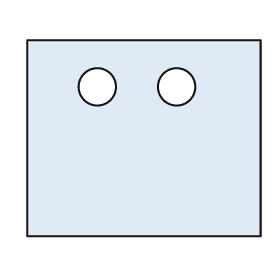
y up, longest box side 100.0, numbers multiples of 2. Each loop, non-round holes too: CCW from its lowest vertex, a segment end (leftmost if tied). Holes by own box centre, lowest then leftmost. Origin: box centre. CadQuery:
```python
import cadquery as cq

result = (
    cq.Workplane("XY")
    .moveTo(-50.0, -42.0)
    .lineTo(50.0, -42.0)
    .lineTo(50.0, 42.0)
    .lineTo(-50.0, 42.0)
    .close()
    .moveTo(-20.0, 22.0)
    .circle(8.0)
    .moveTo(14.0, 22.0)
    .circle(8.0)
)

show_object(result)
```